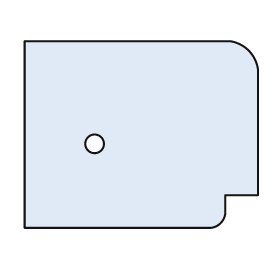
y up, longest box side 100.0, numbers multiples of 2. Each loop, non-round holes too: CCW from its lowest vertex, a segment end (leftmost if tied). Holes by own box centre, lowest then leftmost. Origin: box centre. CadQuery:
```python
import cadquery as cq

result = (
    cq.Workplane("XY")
    .moveTo(-50.0, -40.0)
    .lineTo(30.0, -40.0)
    .threePointArc((34.0, -38.0), (36.0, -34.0))
    .lineTo(36.0, -26.0)
    .lineTo(50.0, -26.0)
    .lineTo(50.0, 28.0)
    .threePointArc((46.0, 36.0), (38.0, 40.0))
    .lineTo(-50.0, 40.0)
    .close()
    .moveTo(-20.0, -4.0)
    .circle(4.0)
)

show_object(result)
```